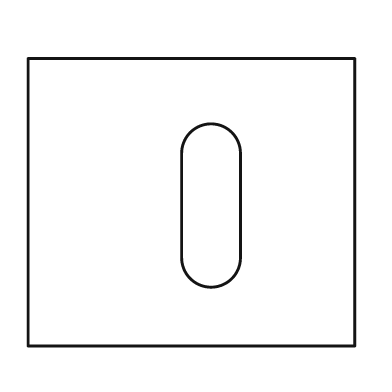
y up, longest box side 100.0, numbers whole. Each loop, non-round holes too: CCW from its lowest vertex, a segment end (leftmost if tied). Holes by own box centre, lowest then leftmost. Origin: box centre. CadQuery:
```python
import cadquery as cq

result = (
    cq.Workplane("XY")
    .moveTo(-50.0, -44.0)
    .lineTo(50.0, -44.0)
    .lineTo(50.0, 44.0)
    .lineTo(-50.0, 44.0)
    .close()
    .moveTo(-3.0, -17.0)
    .threePointArc((6.0, -26.0), (15.0, -17.0))
    .lineTo(15.0, 15.0)
    .threePointArc((6.0, 24.0), (-3.0, 15.0))
    .close()
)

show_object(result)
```